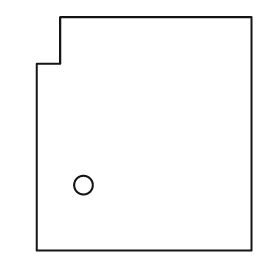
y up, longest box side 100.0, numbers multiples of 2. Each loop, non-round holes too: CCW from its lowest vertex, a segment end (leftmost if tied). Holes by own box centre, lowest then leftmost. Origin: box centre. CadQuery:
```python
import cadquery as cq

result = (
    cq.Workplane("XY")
    .moveTo(-46.0, -50.0)
    .lineTo(46.0, -50.0)
    .lineTo(46.0, 50.0)
    .lineTo(-36.0, 50.0)
    .lineTo(-36.0, 30.0)
    .lineTo(-46.0, 30.0)
    .close()
    .moveTo(-26.0, -22.0)
    .circle(4.0)
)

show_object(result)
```